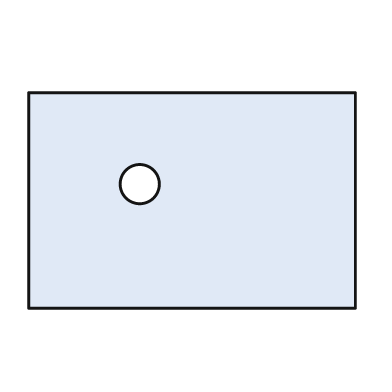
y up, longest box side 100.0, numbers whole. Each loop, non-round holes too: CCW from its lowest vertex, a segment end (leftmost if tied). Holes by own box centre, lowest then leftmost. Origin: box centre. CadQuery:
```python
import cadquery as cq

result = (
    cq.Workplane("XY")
    .moveTo(-50.0, -33.0)
    .lineTo(50.0, -33.0)
    .lineTo(50.0, 33.0)
    .lineTo(-50.0, 33.0)
    .close()
    .moveTo(-16.0, 5.0)
    .circle(6.0)
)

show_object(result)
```